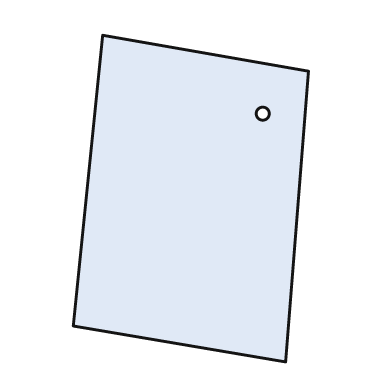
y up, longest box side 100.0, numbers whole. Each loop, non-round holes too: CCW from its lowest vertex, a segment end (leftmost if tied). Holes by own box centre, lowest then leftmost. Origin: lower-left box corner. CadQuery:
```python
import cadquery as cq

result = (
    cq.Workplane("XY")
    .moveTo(65.0, 0.0)
    .lineTo(72.0, 89.0)
    .lineTo(9.0, 100.0)
    .lineTo(0.0, 11.0)
    .close()
    .moveTo(58.0, 76.0)
    .circle(2.0)
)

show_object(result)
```